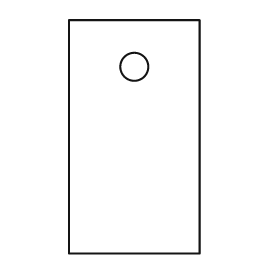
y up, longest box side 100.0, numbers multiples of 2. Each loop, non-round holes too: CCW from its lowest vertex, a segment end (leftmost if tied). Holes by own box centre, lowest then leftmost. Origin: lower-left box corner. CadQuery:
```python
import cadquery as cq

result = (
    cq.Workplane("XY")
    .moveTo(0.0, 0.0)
    .lineTo(56.0, 0.0)
    .lineTo(56.0, 100.0)
    .lineTo(0.0, 100.0)
    .close()
    .moveTo(28.0, 80.0)
    .circle(6.0)
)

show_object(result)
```